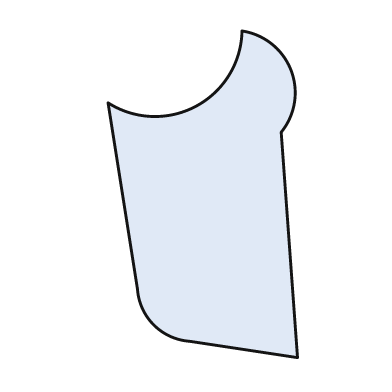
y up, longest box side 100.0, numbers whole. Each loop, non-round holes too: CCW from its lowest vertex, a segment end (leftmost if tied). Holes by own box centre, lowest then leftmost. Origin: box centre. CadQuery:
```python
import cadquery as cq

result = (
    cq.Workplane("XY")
    .moveTo(29.0, -50.0)
    .lineTo(24.0, 19.0)
    .threePointArc((27.0, 38.0), (12.0, 50.0))
    .threePointArc((-2.0, 27.0), (-29.0, 28.0))
    .lineTo(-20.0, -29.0)
    .threePointArc((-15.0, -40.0), (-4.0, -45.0))
    .close()
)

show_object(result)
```